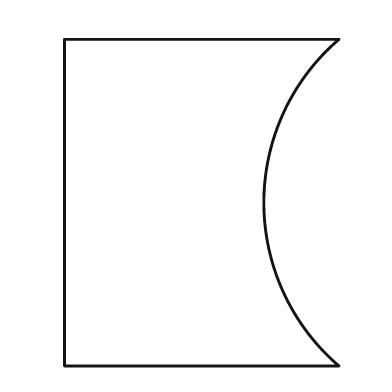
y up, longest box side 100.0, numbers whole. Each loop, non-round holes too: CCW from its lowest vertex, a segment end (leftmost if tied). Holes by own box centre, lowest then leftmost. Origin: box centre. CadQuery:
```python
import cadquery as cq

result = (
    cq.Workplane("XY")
    .moveTo(-42.0, -50.0)
    .lineTo(42.0, -50.0)
    .threePointArc((19.0, 0.0), (42.0, 50.0))
    .lineTo(-42.0, 50.0)
    .close()
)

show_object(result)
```